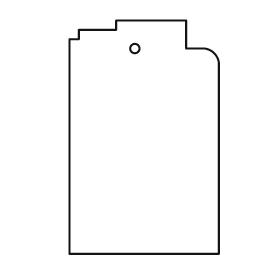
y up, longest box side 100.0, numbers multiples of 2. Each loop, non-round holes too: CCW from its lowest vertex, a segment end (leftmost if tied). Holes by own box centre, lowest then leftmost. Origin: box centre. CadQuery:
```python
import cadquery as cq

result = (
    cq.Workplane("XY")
    .moveTo(-32.0, -50.0)
    .lineTo(32.0, -50.0)
    .lineTo(32.0, 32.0)
    .threePointArc((30.0, 36.0), (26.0, 38.0))
    .lineTo(18.0, 38.0)
    .lineTo(18.0, 50.0)
    .lineTo(-12.0, 50.0)
    .lineTo(-12.0, 46.0)
    .lineTo(-28.0, 46.0)
    .lineTo(-28.0, 42.0)
    .lineTo(-32.0, 42.0)
    .close()
    .moveTo(-4.0, 38.0)
    .circle(2.0)
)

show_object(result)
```